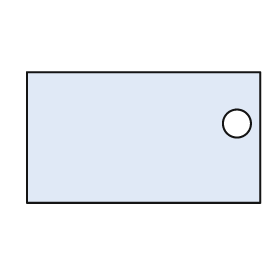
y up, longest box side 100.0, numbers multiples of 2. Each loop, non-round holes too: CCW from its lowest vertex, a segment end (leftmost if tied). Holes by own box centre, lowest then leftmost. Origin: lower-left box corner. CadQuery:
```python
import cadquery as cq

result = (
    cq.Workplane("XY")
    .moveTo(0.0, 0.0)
    .lineTo(100.0, 0.0)
    .lineTo(100.0, 56.0)
    .lineTo(0.0, 56.0)
    .close()
    .moveTo(90.0, 34.0)
    .circle(6.0)
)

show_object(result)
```